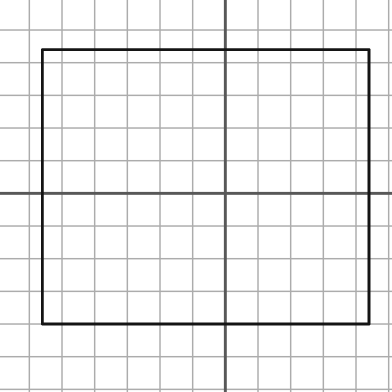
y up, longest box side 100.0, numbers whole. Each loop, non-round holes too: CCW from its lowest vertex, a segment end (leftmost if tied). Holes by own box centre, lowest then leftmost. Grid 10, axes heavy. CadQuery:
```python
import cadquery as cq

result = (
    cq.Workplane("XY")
    .moveTo(-56.0, -40.0)
    .lineTo(44.0, -40.0)
    .lineTo(44.0, 44.0)
    .lineTo(-56.0, 44.0)
    .close()
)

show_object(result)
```